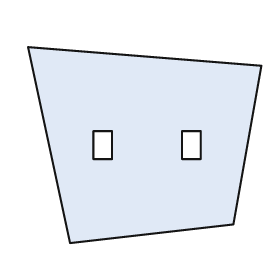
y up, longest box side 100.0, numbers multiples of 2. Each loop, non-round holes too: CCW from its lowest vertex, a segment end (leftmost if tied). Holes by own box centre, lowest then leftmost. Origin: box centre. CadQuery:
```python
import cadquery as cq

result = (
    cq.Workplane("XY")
    .moveTo(-32.0, -42.0)
    .lineTo(38.0, -34.0)
    .lineTo(50.0, 34.0)
    .lineTo(-50.0, 42.0)
    .close()
    .moveTo(-22.0, -6.0)
    .lineTo(-14.0, -6.0)
    .lineTo(-14.0, 6.0)
    .lineTo(-22.0, 6.0)
    .close()
    .moveTo(16.0, -6.0)
    .lineTo(24.0, -6.0)
    .lineTo(24.0, 6.0)
    .lineTo(16.0, 6.0)
    .close()
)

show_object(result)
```